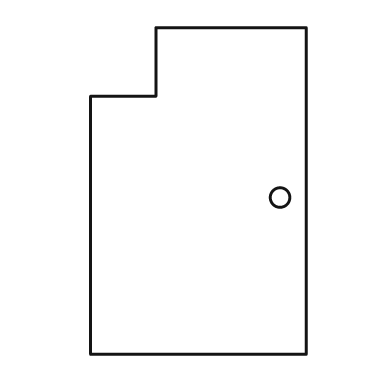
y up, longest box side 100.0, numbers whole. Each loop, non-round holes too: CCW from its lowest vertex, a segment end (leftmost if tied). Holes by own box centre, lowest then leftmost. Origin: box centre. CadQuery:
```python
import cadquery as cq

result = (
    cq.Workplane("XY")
    .moveTo(-33.0, -50.0)
    .lineTo(33.0, -50.0)
    .lineTo(33.0, 50.0)
    .lineTo(-13.0, 50.0)
    .lineTo(-13.0, 29.0)
    .lineTo(-33.0, 29.0)
    .close()
    .moveTo(25.0, -2.0)
    .circle(3.0)
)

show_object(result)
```